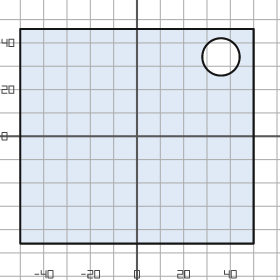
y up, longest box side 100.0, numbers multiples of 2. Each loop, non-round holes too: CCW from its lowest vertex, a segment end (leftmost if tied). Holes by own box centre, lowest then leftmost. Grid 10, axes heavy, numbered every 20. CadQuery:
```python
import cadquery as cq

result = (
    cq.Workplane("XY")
    .moveTo(-50.0, -46.0)
    .lineTo(50.0, -46.0)
    .lineTo(50.0, 46.0)
    .lineTo(-50.0, 46.0)
    .close()
    .moveTo(36.0, 34.0)
    .circle(8.0)
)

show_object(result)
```